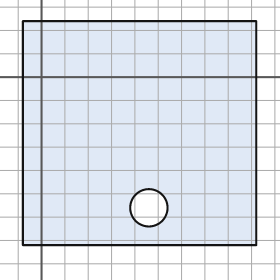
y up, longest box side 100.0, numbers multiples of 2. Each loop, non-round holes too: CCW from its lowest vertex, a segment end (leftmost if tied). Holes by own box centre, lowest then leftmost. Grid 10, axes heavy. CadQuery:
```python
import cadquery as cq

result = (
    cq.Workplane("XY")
    .moveTo(-8.0, -72.0)
    .lineTo(92.0, -72.0)
    .lineTo(92.0, 24.0)
    .lineTo(-8.0, 24.0)
    .close()
    .moveTo(46.0, -56.0)
    .circle(8.0)
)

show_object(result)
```